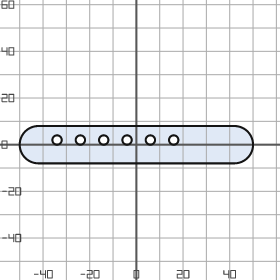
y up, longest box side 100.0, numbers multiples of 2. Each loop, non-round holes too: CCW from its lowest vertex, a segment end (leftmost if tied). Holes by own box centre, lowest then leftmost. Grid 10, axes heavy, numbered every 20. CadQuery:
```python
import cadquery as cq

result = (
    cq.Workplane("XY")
    .moveTo(-42.0, -8.0)
    .lineTo(42.0, -8.0)
    .threePointArc((50.0, 0.0), (42.0, 8.0))
    .lineTo(-42.0, 8.0)
    .threePointArc((-50.0, 0.0), (-42.0, -8.0))
    .close()
    .moveTo(-34.0, 2.0)
    .circle(2.0)
    .moveTo(-24.0, 2.0)
    .circle(2.0)
    .moveTo(-14.0, 2.0)
    .circle(2.0)
    .moveTo(-4.0, 2.0)
    .circle(2.0)
    .moveTo(6.0, 2.0)
    .circle(2.0)
    .moveTo(16.0, 2.0)
    .circle(2.0)
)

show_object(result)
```